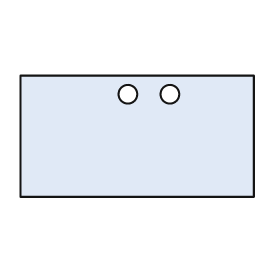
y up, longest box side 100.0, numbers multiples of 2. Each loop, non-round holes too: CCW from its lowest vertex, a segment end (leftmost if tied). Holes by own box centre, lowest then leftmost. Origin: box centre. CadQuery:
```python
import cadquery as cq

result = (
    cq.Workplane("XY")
    .moveTo(-50.0, -26.0)
    .lineTo(50.0, -26.0)
    .lineTo(50.0, 26.0)
    .lineTo(-50.0, 26.0)
    .close()
    .moveTo(-4.0, 18.0)
    .circle(4.0)
    .moveTo(14.0, 18.0)
    .circle(4.0)
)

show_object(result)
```